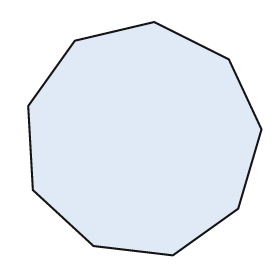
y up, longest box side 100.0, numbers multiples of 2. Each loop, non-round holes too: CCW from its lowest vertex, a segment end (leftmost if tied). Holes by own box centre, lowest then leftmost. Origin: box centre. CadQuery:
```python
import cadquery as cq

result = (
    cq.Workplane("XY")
    .moveTo(12.0, -50.0)
    .lineTo(40.0, -30.0)
    .lineTo(50.0, 4.0)
    .lineTo(36.0, 34.0)
    .lineTo(4.0, 50.0)
    .lineTo(-30.0, 42.0)
    .lineTo(-50.0, 14.0)
    .lineTo(-48.0, -22.0)
    .lineTo(-22.0, -46.0)
    .close()
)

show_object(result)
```